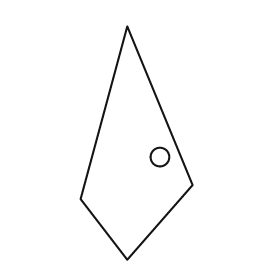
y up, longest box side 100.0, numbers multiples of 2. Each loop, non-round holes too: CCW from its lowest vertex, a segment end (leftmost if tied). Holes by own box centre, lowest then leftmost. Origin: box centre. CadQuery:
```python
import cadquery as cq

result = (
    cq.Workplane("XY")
    .moveTo(-4.0, -50.0)
    .lineTo(24.0, -18.0)
    .lineTo(-4.0, 50.0)
    .lineTo(-24.0, -24.0)
    .close()
    .moveTo(10.0, -6.0)
    .circle(4.0)
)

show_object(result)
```